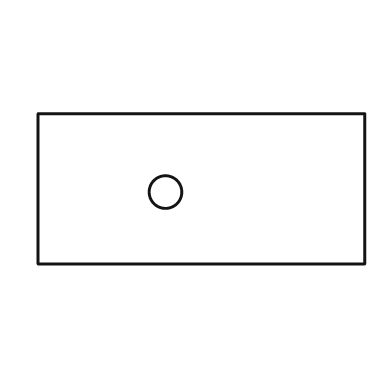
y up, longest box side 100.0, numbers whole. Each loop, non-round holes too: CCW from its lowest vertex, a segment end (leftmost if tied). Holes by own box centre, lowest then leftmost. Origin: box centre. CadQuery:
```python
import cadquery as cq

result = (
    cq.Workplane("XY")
    .moveTo(-50.0, -23.0)
    .lineTo(50.0, -23.0)
    .lineTo(50.0, 23.0)
    .lineTo(-50.0, 23.0)
    .close()
    .moveTo(-11.0, -1.0)
    .circle(5.0)
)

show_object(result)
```